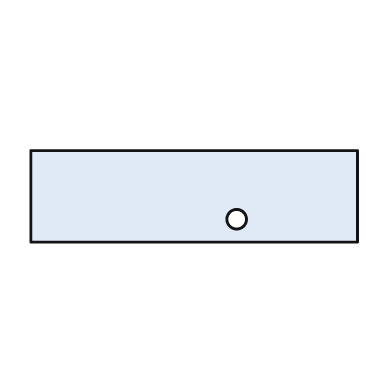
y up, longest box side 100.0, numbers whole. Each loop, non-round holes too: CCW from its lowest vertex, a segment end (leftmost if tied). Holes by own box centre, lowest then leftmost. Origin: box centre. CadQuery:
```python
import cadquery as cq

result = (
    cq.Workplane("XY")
    .moveTo(-50.0, -14.0)
    .lineTo(50.0, -14.0)
    .lineTo(50.0, 14.0)
    .lineTo(-50.0, 14.0)
    .close()
    .moveTo(13.0, -7.0)
    .circle(3.0)
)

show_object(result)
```